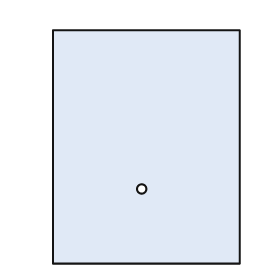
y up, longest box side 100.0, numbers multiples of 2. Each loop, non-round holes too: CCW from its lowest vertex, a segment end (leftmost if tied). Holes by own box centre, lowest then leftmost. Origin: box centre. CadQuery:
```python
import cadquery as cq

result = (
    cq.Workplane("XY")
    .moveTo(-40.0, -50.0)
    .lineTo(40.0, -50.0)
    .lineTo(40.0, 50.0)
    .lineTo(-40.0, 50.0)
    .close()
    .moveTo(-2.0, -18.0)
    .circle(2.0)
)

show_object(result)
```